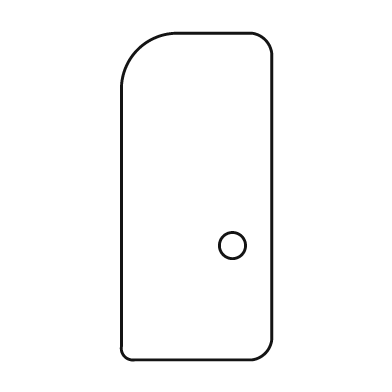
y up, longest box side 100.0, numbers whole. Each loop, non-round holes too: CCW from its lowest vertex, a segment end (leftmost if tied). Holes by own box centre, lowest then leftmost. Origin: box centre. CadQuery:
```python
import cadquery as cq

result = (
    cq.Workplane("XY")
    .moveTo(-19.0, -50.0)
    .lineTo(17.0, -50.0)
    .threePointArc((21.0, -48.0), (23.0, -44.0))
    .lineTo(23.0, 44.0)
    .threePointArc((21.0, 48.0), (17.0, 50.0))
    .lineTo(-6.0, 50.0)
    .threePointArc((-18.0, 45.0), (-23.0, 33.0))
    .lineTo(-23.0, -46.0)
    .threePointArc((-22.0, -49.0), (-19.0, -50.0))
    .close()
    .moveTo(11.0, -15.0)
    .circle(4.0)
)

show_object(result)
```